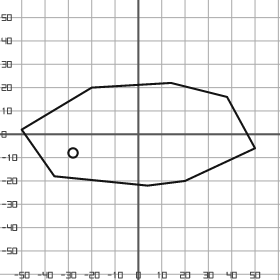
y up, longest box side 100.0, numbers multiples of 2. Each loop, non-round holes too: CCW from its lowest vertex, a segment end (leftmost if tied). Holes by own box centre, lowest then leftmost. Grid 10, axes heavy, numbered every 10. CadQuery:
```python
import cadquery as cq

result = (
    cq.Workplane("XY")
    .moveTo(4.0, -22.0)
    .lineTo(20.0, -20.0)
    .lineTo(50.0, -6.0)
    .lineTo(38.0, 16.0)
    .lineTo(14.0, 22.0)
    .lineTo(-20.0, 20.0)
    .lineTo(-50.0, 2.0)
    .lineTo(-36.0, -18.0)
    .close()
    .moveTo(-28.0, -8.0)
    .circle(2.0)
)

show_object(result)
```